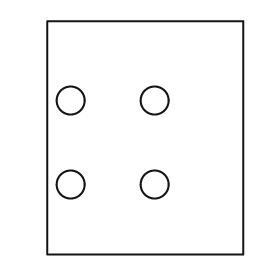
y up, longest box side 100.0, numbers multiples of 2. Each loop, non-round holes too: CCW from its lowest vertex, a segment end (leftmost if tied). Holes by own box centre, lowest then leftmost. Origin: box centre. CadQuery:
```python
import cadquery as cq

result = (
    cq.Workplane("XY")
    .moveTo(-42.0, -50.0)
    .lineTo(42.0, -50.0)
    .lineTo(42.0, 50.0)
    .lineTo(-42.0, 50.0)
    .close()
    .moveTo(-32.0, -20.0)
    .circle(6.0)
    .moveTo(4.0, -20.0)
    .circle(6.0)
    .moveTo(-32.0, 16.0)
    .circle(6.0)
    .moveTo(4.0, 16.0)
    .circle(6.0)
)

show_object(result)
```